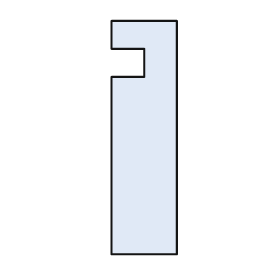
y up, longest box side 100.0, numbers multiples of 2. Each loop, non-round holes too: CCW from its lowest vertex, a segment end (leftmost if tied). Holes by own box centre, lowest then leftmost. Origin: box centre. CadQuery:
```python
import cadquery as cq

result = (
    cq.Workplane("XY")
    .moveTo(-14.0, -50.0)
    .lineTo(14.0, -50.0)
    .lineTo(14.0, 50.0)
    .lineTo(-14.0, 50.0)
    .lineTo(-14.0, 38.0)
    .lineTo(0.0, 38.0)
    .lineTo(0.0, 26.0)
    .lineTo(-14.0, 26.0)
    .close()
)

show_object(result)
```